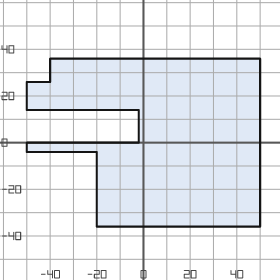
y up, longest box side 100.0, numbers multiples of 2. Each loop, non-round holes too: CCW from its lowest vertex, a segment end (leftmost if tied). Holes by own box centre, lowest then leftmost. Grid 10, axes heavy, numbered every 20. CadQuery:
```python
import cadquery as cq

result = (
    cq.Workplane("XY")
    .moveTo(-20.0, -36.0)
    .lineTo(50.0, -36.0)
    .lineTo(50.0, 36.0)
    .lineTo(-40.0, 36.0)
    .lineTo(-40.0, 26.0)
    .lineTo(-50.0, 26.0)
    .lineTo(-50.0, 14.0)
    .lineTo(-2.0, 14.0)
    .lineTo(-2.0, 0.0)
    .lineTo(-50.0, 0.0)
    .lineTo(-50.0, -4.0)
    .lineTo(-20.0, -4.0)
    .close()
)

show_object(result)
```